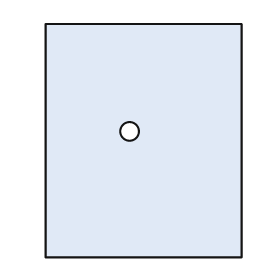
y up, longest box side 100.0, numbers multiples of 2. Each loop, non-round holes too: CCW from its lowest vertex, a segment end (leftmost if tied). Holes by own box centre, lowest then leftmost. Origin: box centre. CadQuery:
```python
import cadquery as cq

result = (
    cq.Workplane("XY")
    .moveTo(-42.0, -50.0)
    .lineTo(42.0, -50.0)
    .lineTo(42.0, 50.0)
    .lineTo(-42.0, 50.0)
    .close()
    .moveTo(-6.0, 4.0)
    .circle(4.0)
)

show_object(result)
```